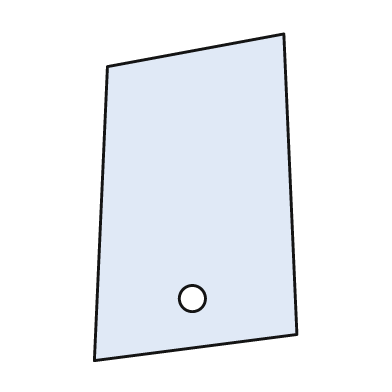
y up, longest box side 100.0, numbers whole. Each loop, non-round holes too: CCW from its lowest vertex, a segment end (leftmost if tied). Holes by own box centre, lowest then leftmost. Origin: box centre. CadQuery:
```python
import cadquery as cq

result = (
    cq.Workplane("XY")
    .moveTo(-31.0, -50.0)
    .lineTo(31.0, -42.0)
    .lineTo(27.0, 50.0)
    .lineTo(-27.0, 40.0)
    .close()
    .moveTo(-1.0, -31.0)
    .circle(4.0)
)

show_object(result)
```